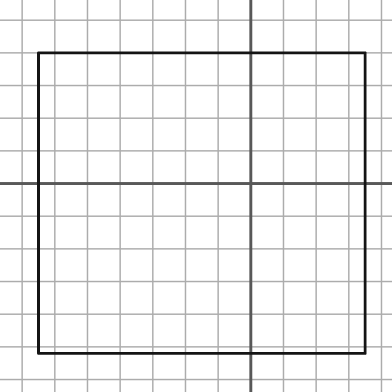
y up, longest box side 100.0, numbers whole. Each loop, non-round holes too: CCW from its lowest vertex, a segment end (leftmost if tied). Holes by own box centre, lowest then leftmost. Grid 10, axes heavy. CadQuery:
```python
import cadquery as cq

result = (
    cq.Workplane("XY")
    .moveTo(-65.0, -52.0)
    .lineTo(35.0, -52.0)
    .lineTo(35.0, 40.0)
    .lineTo(-65.0, 40.0)
    .close()
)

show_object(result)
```